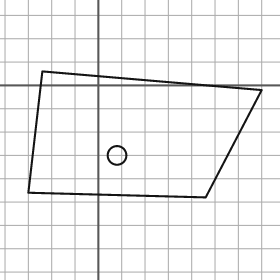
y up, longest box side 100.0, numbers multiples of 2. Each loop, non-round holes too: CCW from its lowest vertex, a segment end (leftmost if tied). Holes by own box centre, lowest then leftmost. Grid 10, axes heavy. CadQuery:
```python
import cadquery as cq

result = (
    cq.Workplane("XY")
    .moveTo(46.0, -48.0)
    .lineTo(70.0, -2.0)
    .lineTo(-24.0, 6.0)
    .lineTo(-30.0, -46.0)
    .close()
    .moveTo(8.0, -30.0)
    .circle(4.0)
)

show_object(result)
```